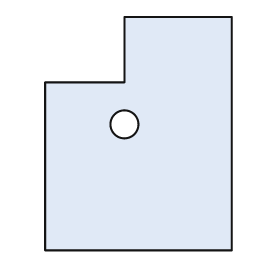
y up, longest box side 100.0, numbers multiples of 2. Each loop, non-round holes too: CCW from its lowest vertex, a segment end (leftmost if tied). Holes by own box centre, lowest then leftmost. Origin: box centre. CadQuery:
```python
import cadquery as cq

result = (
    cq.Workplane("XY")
    .moveTo(-40.0, -50.0)
    .lineTo(40.0, -50.0)
    .lineTo(40.0, 50.0)
    .lineTo(-6.0, 50.0)
    .lineTo(-6.0, 22.0)
    .lineTo(-40.0, 22.0)
    .close()
    .moveTo(-6.0, 4.0)
    .circle(6.0)
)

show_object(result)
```